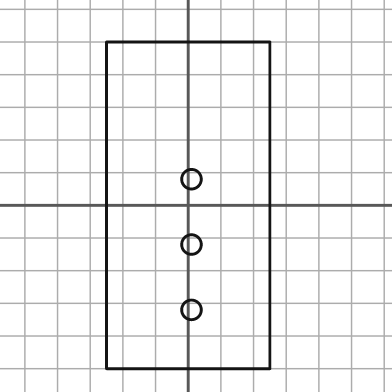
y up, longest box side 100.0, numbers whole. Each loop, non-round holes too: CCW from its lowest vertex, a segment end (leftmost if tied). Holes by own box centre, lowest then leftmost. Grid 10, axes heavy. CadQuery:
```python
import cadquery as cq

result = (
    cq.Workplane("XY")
    .moveTo(-25.0, -50.0)
    .lineTo(25.0, -50.0)
    .lineTo(25.0, 50.0)
    .lineTo(-25.0, 50.0)
    .close()
    .moveTo(1.0, -32.0)
    .circle(3.0)
    .moveTo(1.0, -12.0)
    .circle(3.0)
    .moveTo(1.0, 8.0)
    .circle(3.0)
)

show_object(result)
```